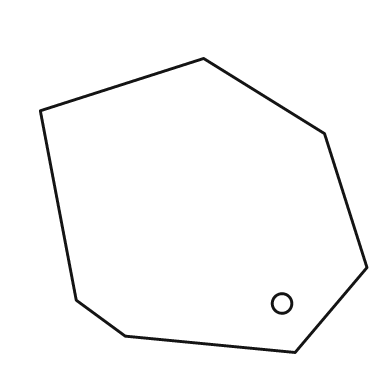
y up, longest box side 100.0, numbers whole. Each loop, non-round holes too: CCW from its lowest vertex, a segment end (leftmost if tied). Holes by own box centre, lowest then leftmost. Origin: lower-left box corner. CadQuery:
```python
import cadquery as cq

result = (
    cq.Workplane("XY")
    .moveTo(78.0, 0.0)
    .lineTo(100.0, 26.0)
    .lineTo(87.0, 67.0)
    .lineTo(50.0, 90.0)
    .lineTo(0.0, 74.0)
    .lineTo(11.0, 16.0)
    .lineTo(26.0, 5.0)
    .close()
    .moveTo(74.0, 15.0)
    .circle(3.0)
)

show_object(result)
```